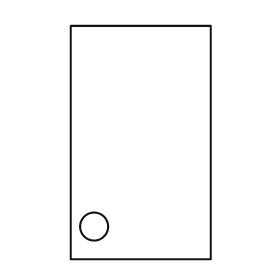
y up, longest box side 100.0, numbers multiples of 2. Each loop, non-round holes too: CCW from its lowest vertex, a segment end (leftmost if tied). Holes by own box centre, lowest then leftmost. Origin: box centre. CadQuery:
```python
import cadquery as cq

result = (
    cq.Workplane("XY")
    .moveTo(-30.0, -50.0)
    .lineTo(30.0, -50.0)
    .lineTo(30.0, 50.0)
    .lineTo(-30.0, 50.0)
    .close()
    .moveTo(-20.0, -36.0)
    .circle(6.0)
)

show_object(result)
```